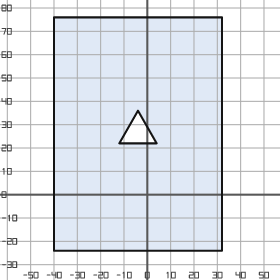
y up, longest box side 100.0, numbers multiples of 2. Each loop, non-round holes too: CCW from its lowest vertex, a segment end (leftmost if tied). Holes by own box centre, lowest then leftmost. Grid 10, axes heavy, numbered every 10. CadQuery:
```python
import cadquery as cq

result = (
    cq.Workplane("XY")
    .moveTo(-40.0, -24.0)
    .lineTo(32.0, -24.0)
    .lineTo(32.0, 76.0)
    .lineTo(-40.0, 76.0)
    .close()
    .moveTo(-12.0, 22.0)
    .lineTo(4.0, 22.0)
    .lineTo(-4.0, 36.0)
    .close()
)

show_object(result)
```